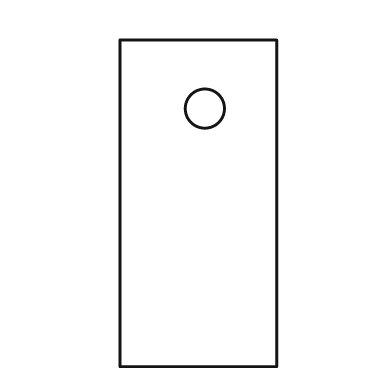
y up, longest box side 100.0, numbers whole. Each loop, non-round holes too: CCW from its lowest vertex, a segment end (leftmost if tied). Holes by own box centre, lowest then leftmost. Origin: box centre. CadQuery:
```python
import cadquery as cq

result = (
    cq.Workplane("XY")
    .moveTo(-24.0, -50.0)
    .lineTo(24.0, -50.0)
    .lineTo(24.0, 50.0)
    .lineTo(-24.0, 50.0)
    .close()
    .moveTo(2.0, 29.0)
    .circle(6.0)
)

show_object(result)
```